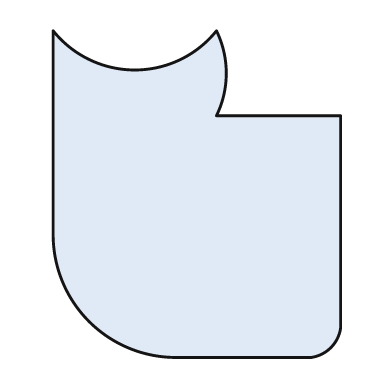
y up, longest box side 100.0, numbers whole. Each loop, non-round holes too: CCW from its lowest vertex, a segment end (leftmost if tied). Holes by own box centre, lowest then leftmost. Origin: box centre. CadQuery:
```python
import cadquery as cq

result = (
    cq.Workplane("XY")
    .moveTo(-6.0, -50.0)
    .lineTo(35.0, -50.0)
    .threePointArc((41.0, -47.0), (44.0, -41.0))
    .lineTo(44.0, 24.0)
    .lineTo(6.0, 24.0)
    .threePointArc((9.0, 37.0), (6.0, 50.0))
    .threePointArc((-19.0, 38.0), (-44.0, 50.0))
    .lineTo(-44.0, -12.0)
    .threePointArc((-33.0, -39.0), (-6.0, -50.0))
    .close()
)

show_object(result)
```